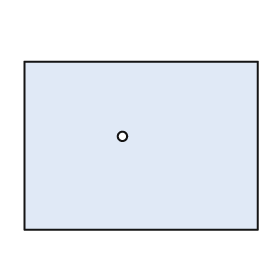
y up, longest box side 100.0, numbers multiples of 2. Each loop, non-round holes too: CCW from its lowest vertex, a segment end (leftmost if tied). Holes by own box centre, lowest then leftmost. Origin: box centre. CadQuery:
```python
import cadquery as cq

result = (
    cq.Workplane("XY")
    .moveTo(-50.0, -36.0)
    .lineTo(50.0, -36.0)
    .lineTo(50.0, 36.0)
    .lineTo(-50.0, 36.0)
    .close()
    .moveTo(-8.0, 4.0)
    .circle(2.0)
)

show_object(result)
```